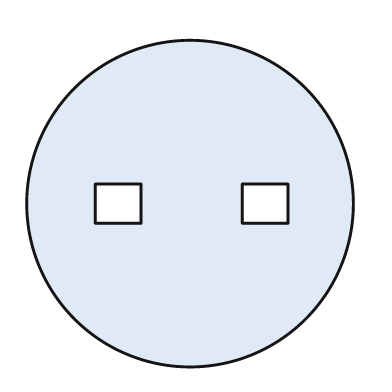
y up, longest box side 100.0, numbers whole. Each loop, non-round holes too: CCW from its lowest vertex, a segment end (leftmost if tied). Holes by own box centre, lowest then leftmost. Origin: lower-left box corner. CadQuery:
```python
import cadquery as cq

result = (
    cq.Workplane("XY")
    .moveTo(50.0, 50.0)
    .circle(50.0)
    .moveTo(21.0, 44.0)
    .lineTo(35.0, 44.0)
    .lineTo(35.0, 56.0)
    .lineTo(21.0, 56.0)
    .close()
    .moveTo(66.0, 44.0)
    .lineTo(80.0, 44.0)
    .lineTo(80.0, 56.0)
    .lineTo(66.0, 56.0)
    .close()
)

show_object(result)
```